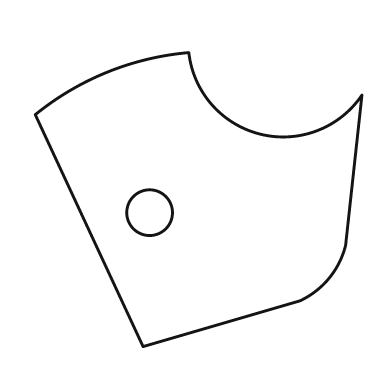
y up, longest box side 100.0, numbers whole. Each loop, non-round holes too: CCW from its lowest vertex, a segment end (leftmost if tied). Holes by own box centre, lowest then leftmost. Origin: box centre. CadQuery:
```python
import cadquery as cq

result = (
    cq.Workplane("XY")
    .moveTo(-17.0, -45.0)
    .lineTo(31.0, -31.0)
    .threePointArc((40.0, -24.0), (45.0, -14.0))
    .lineTo(50.0, 32.0)
    .threePointArc((19.0, 20.0), (-3.0, 45.0))
    .threePointArc((-28.0, 39.0), (-50.0, 26.0))
    .close()
    .moveTo(-15.0, -4.0)
    .circle(7.0)
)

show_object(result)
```